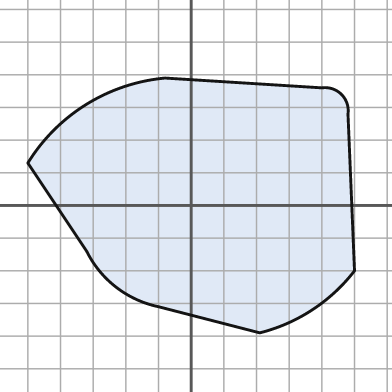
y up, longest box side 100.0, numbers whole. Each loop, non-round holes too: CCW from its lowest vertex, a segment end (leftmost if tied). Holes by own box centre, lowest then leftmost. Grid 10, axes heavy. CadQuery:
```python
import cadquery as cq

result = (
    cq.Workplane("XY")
    .moveTo(21.0, -39.0)
    .threePointArc((37.0, -32.0), (50.0, -20.0))
    .lineTo(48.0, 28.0)
    .threePointArc((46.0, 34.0), (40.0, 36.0))
    .lineTo(-8.0, 39.0)
    .threePointArc((-32.0, 31.0), (-50.0, 13.0))
    .lineTo(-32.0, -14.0)
    .threePointArc((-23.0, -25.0), (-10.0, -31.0))
    .close()
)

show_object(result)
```